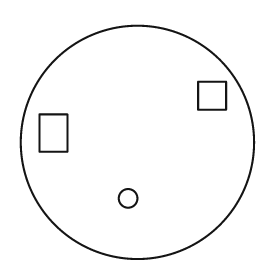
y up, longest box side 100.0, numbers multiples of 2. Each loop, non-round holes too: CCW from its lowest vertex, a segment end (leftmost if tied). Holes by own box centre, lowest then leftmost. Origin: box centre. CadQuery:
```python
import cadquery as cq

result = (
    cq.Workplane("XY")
    .moveTo(0.0, 0.0)
    .circle(50.0)
    .moveTo(-4.0, -24.0)
    .circle(4.0)
    .moveTo(-42.0, -4.0)
    .lineTo(-30.0, -4.0)
    .lineTo(-30.0, 12.0)
    .lineTo(-42.0, 12.0)
    .close()
    .moveTo(26.0, 14.0)
    .lineTo(38.0, 14.0)
    .lineTo(38.0, 26.0)
    .lineTo(26.0, 26.0)
    .close()
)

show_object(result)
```